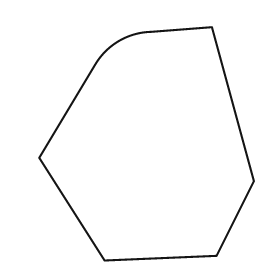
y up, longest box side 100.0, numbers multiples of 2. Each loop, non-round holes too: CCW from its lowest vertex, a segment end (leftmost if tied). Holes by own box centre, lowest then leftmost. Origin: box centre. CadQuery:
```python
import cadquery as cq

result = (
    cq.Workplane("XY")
    .moveTo(-18.0, -50.0)
    .lineTo(30.0, -48.0)
    .lineTo(46.0, -16.0)
    .lineTo(28.0, 50.0)
    .lineTo(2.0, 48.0)
    .threePointArc((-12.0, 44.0), (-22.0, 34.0))
    .lineTo(-46.0, -6.0)
    .close()
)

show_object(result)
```